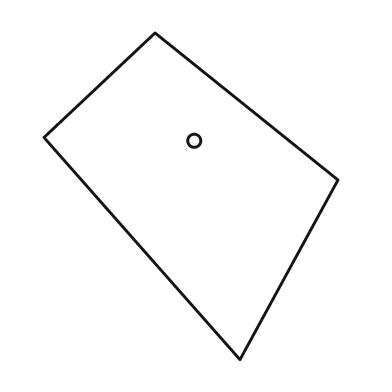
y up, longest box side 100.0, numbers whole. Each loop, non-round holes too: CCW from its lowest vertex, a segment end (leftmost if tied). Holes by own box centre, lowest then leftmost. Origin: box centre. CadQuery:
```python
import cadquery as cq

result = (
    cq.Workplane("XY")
    .moveTo(15.0, -50.0)
    .lineTo(45.0, 5.0)
    .lineTo(-11.0, 50.0)
    .lineTo(-45.0, 18.0)
    .close()
    .moveTo(1.0, 17.0)
    .circle(2.0)
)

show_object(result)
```